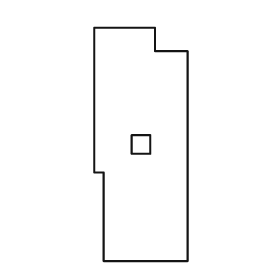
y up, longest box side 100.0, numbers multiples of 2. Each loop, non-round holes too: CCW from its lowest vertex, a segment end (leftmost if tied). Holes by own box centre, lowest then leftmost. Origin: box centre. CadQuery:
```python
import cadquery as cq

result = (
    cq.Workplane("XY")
    .moveTo(-16.0, -50.0)
    .lineTo(20.0, -50.0)
    .lineTo(20.0, 40.0)
    .lineTo(6.0, 40.0)
    .lineTo(6.0, 50.0)
    .lineTo(-20.0, 50.0)
    .lineTo(-20.0, -12.0)
    .lineTo(-16.0, -12.0)
    .close()
    .moveTo(-4.0, -4.0)
    .lineTo(4.0, -4.0)
    .lineTo(4.0, 4.0)
    .lineTo(-4.0, 4.0)
    .close()
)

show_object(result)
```